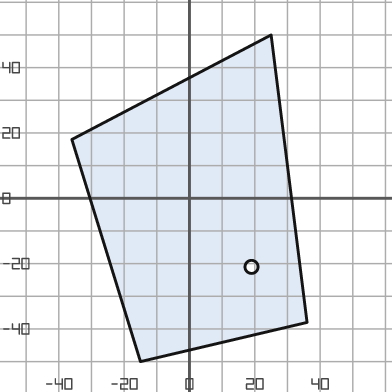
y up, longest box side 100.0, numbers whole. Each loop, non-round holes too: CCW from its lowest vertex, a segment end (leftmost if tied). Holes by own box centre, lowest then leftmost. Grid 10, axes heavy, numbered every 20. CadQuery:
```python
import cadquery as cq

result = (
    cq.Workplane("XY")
    .moveTo(-15.0, -50.0)
    .lineTo(36.0, -38.0)
    .lineTo(25.0, 50.0)
    .lineTo(-36.0, 18.0)
    .close()
    .moveTo(19.0, -21.0)
    .circle(2.0)
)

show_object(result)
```